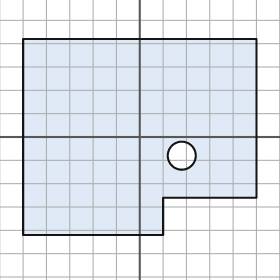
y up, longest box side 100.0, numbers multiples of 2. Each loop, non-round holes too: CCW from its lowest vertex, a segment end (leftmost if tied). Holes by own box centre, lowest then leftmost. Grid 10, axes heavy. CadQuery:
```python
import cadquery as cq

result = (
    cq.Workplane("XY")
    .moveTo(-50.0, -42.0)
    .lineTo(10.0, -42.0)
    .lineTo(10.0, -26.0)
    .lineTo(50.0, -26.0)
    .lineTo(50.0, 42.0)
    .lineTo(-50.0, 42.0)
    .close()
    .moveTo(18.0, -8.0)
    .circle(6.0)
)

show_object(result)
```